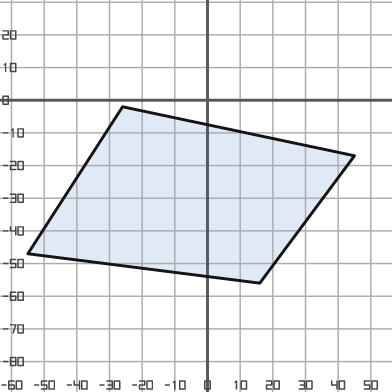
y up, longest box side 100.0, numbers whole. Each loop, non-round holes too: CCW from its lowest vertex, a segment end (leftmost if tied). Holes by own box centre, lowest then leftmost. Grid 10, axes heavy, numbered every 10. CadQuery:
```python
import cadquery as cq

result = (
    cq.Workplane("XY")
    .moveTo(16.0, -56.0)
    .lineTo(45.0, -17.0)
    .lineTo(-26.0, -2.0)
    .lineTo(-55.0, -47.0)
    .close()
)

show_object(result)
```